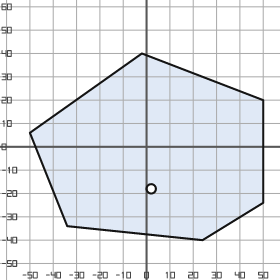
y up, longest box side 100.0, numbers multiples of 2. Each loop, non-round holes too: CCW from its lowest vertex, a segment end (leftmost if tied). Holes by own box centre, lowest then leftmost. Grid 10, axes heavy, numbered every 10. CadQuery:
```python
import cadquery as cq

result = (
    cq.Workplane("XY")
    .moveTo(24.0, -40.0)
    .lineTo(50.0, -24.0)
    .lineTo(50.0, 20.0)
    .lineTo(-2.0, 40.0)
    .lineTo(-50.0, 6.0)
    .lineTo(-34.0, -34.0)
    .close()
    .moveTo(2.0, -18.0)
    .circle(2.0)
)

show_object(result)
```